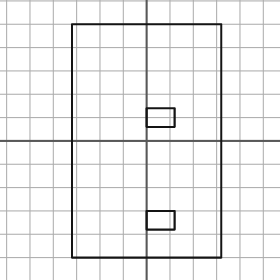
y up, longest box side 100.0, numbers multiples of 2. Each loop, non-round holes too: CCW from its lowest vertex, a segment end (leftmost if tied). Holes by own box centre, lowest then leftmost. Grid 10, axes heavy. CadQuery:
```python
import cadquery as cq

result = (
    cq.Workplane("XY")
    .moveTo(-32.0, -50.0)
    .lineTo(32.0, -50.0)
    .lineTo(32.0, 50.0)
    .lineTo(-32.0, 50.0)
    .close()
    .moveTo(0.0, -38.0)
    .lineTo(12.0, -38.0)
    .lineTo(12.0, -30.0)
    .lineTo(0.0, -30.0)
    .close()
    .moveTo(0.0, 6.0)
    .lineTo(12.0, 6.0)
    .lineTo(12.0, 14.0)
    .lineTo(0.0, 14.0)
    .close()
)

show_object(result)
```